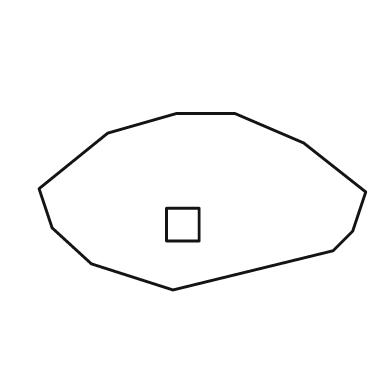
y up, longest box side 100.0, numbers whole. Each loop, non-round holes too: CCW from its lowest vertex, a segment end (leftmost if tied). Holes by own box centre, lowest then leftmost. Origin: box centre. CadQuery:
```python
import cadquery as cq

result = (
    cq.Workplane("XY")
    .moveTo(-9.0, -27.0)
    .lineTo(40.0, -15.0)
    .lineTo(46.0, -9.0)
    .lineTo(50.0, 3.0)
    .lineTo(31.0, 18.0)
    .lineTo(10.0, 27.0)
    .lineTo(-8.0, 27.0)
    .lineTo(-29.0, 21.0)
    .lineTo(-50.0, 4.0)
    .lineTo(-46.0, -8.0)
    .lineTo(-34.0, -19.0)
    .close()
    .moveTo(-11.0, -12.0)
    .lineTo(-1.0, -12.0)
    .lineTo(-1.0, -2.0)
    .lineTo(-11.0, -2.0)
    .close()
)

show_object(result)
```